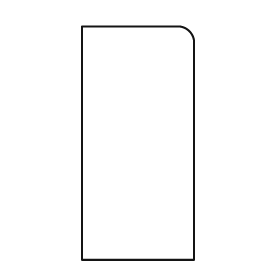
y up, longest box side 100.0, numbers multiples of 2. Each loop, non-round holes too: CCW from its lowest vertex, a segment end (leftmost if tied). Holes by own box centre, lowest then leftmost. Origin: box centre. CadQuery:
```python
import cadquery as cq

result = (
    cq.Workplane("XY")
    .moveTo(-24.0, -50.0)
    .lineTo(24.0, -50.0)
    .lineTo(24.0, 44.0)
    .threePointArc((22.0, 48.0), (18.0, 50.0))
    .lineTo(-24.0, 50.0)
    .close()
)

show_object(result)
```